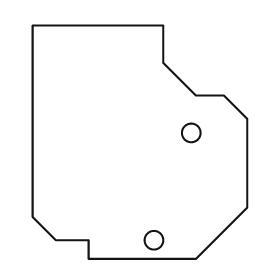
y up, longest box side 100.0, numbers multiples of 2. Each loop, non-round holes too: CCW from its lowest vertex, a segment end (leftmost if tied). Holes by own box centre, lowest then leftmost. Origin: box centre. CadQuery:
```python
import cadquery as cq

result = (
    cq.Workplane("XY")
    .moveTo(-22.0, -50.0)
    .lineTo(24.0, -50.0)
    .lineTo(46.0, -28.0)
    .lineTo(46.0, 10.0)
    .lineTo(36.0, 20.0)
    .lineTo(24.0, 20.0)
    .lineTo(10.0, 34.0)
    .lineTo(10.0, 50.0)
    .lineTo(-46.0, 50.0)
    .lineTo(-46.0, -32.0)
    .lineTo(-36.0, -42.0)
    .lineTo(-22.0, -42.0)
    .close()
    .moveTo(6.0, -42.0)
    .circle(4.0)
    .moveTo(22.0, 4.0)
    .circle(4.0)
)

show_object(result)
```